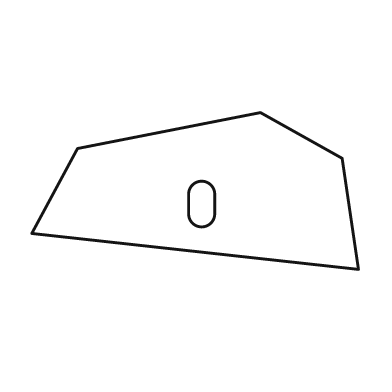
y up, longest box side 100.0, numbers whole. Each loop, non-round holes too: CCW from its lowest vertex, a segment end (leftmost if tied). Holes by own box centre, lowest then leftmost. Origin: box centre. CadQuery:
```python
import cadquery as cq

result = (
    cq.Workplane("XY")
    .moveTo(50.0, -24.0)
    .lineTo(45.0, 10.0)
    .lineTo(20.0, 24.0)
    .lineTo(-36.0, 13.0)
    .lineTo(-50.0, -13.0)
    .close()
    .moveTo(-2.0, -7.0)
    .threePointArc((2.0, -11.0), (6.0, -7.0))
    .lineTo(6.0, -1.0)
    .threePointArc((2.0, 3.0), (-2.0, -1.0))
    .close()
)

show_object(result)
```